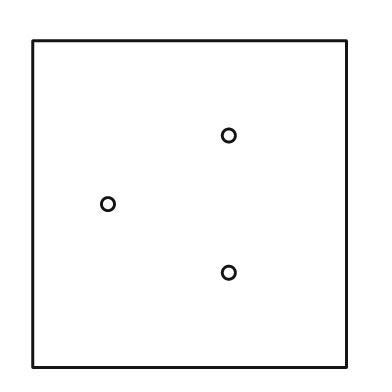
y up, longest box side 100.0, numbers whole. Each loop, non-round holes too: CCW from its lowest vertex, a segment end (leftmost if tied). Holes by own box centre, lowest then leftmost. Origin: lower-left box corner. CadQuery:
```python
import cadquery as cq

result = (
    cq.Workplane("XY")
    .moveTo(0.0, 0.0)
    .lineTo(96.0, 0.0)
    .lineTo(96.0, 100.0)
    .lineTo(0.0, 100.0)
    .close()
    .moveTo(60.0, 29.0)
    .circle(2.0)
    .moveTo(23.0, 50.0)
    .circle(2.0)
    .moveTo(60.0, 71.0)
    .circle(2.0)
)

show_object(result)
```